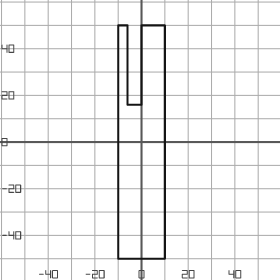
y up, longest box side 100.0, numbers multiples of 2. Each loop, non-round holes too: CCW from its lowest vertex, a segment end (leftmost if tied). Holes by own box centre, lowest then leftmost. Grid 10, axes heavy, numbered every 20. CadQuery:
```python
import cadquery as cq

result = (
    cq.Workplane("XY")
    .moveTo(-10.0, -50.0)
    .lineTo(10.0, -50.0)
    .lineTo(10.0, 50.0)
    .lineTo(0.0, 50.0)
    .lineTo(0.0, 16.0)
    .lineTo(-6.0, 16.0)
    .lineTo(-6.0, 50.0)
    .lineTo(-10.0, 50.0)
    .close()
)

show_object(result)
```